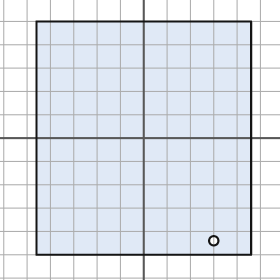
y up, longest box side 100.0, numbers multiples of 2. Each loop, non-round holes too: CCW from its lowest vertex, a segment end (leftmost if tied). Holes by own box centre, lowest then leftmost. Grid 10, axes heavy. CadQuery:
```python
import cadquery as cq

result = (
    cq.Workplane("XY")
    .moveTo(-46.0, -50.0)
    .lineTo(46.0, -50.0)
    .lineTo(46.0, 50.0)
    .lineTo(-46.0, 50.0)
    .close()
    .moveTo(30.0, -44.0)
    .circle(2.0)
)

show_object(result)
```